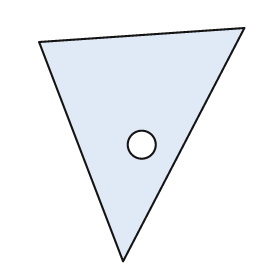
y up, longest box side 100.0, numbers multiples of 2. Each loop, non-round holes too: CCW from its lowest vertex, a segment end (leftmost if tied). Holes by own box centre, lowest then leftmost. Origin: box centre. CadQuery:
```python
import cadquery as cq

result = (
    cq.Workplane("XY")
    .moveTo(-8.0, -50.0)
    .lineTo(44.0, 50.0)
    .lineTo(-44.0, 44.0)
    .close()
    .moveTo(0.0, 0.0)
    .circle(6.0)
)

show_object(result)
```